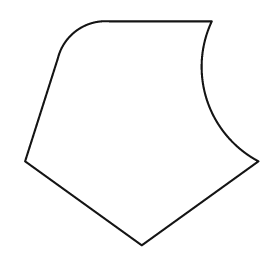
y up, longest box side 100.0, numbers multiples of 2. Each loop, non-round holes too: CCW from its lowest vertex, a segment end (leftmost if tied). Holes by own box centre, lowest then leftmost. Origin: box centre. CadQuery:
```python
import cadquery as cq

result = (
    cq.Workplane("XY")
    .moveTo(0.0, -48.0)
    .lineTo(50.0, -12.0)
    .threePointArc((28.0, 14.0), (30.0, 48.0))
    .lineTo(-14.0, 48.0)
    .threePointArc((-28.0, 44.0), (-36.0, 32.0))
    .lineTo(-50.0, -12.0)
    .close()
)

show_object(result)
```